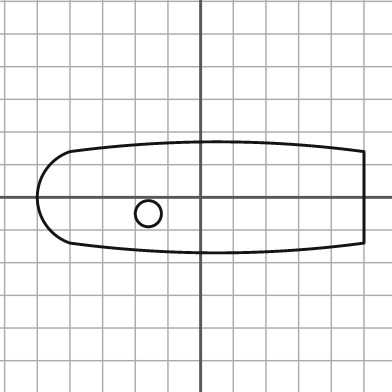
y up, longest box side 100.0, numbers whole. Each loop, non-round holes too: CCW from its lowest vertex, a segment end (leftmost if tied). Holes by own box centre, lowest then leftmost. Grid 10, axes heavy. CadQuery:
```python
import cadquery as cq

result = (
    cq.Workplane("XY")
    .moveTo(-40.0, -14.0)
    .threePointArc((5.0, -17.0), (50.0, -14.0))
    .lineTo(50.0, 14.0)
    .threePointArc((5.0, 17.0), (-40.0, 14.0))
    .threePointArc((-50.0, 0.0), (-40.0, -14.0))
    .close()
    .moveTo(-16.0, -5.0)
    .circle(4.0)
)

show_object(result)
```